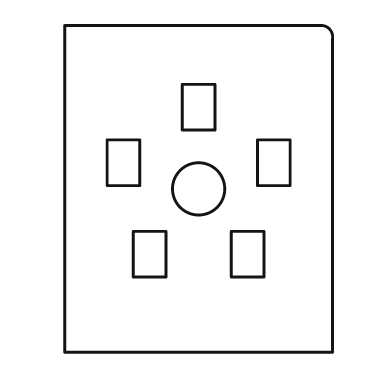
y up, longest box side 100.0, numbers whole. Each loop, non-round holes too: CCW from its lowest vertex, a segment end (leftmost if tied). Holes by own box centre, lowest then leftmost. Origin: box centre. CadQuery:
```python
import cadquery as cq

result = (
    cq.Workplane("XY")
    .moveTo(-41.0, -50.0)
    .lineTo(41.0, -50.0)
    .lineTo(41.0, 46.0)
    .threePointArc((40.0, 49.0), (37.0, 50.0))
    .lineTo(-41.0, 50.0)
    .close()
    .moveTo(-20.0, -27.0)
    .lineTo(-10.0, -27.0)
    .lineTo(-10.0, -13.0)
    .lineTo(-20.0, -13.0)
    .close()
    .moveTo(10.0, -27.0)
    .lineTo(20.0, -27.0)
    .lineTo(20.0, -13.0)
    .lineTo(10.0, -13.0)
    .close()
    .moveTo(0.0, 0.0)
    .circle(8.0)
    .moveTo(-28.0, 1.0)
    .lineTo(-18.0, 1.0)
    .lineTo(-18.0, 15.0)
    .lineTo(-28.0, 15.0)
    .close()
    .moveTo(18.0, 1.0)
    .lineTo(28.0, 1.0)
    .lineTo(28.0, 15.0)
    .lineTo(18.0, 15.0)
    .close()
    .moveTo(-5.0, 18.0)
    .lineTo(5.0, 18.0)
    .lineTo(5.0, 32.0)
    .lineTo(-5.0, 32.0)
    .close()
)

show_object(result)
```